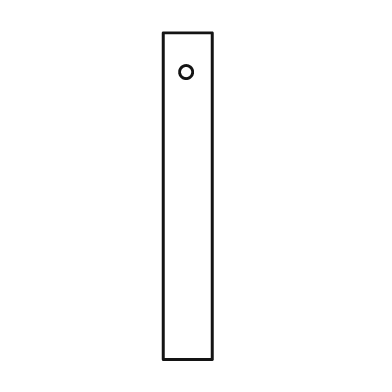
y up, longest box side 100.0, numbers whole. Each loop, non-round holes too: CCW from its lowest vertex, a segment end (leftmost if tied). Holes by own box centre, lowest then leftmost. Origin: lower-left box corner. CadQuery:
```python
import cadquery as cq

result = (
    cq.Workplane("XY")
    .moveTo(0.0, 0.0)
    .lineTo(15.0, 0.0)
    .lineTo(15.0, 100.0)
    .lineTo(0.0, 100.0)
    .close()
    .moveTo(7.0, 88.0)
    .circle(2.0)
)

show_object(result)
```